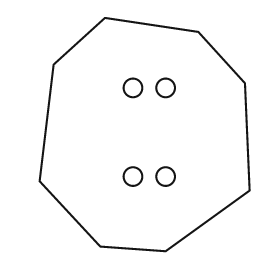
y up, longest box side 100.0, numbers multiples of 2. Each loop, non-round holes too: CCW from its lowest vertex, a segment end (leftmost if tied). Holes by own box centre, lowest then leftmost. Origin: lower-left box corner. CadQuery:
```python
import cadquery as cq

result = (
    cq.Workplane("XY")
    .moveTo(54.0, 0.0)
    .lineTo(90.0, 26.0)
    .lineTo(88.0, 72.0)
    .lineTo(68.0, 94.0)
    .lineTo(28.0, 100.0)
    .lineTo(6.0, 80.0)
    .lineTo(0.0, 30.0)
    .lineTo(26.0, 2.0)
    .close()
    .moveTo(40.0, 32.0)
    .circle(4.0)
    .moveTo(54.0, 32.0)
    .circle(4.0)
    .moveTo(40.0, 70.0)
    .circle(4.0)
    .moveTo(54.0, 70.0)
    .circle(4.0)
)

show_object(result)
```